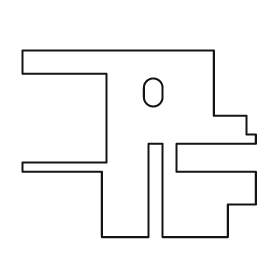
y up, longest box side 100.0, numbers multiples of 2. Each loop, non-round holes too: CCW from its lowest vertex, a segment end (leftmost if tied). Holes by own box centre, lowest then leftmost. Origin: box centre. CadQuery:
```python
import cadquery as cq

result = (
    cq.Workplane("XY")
    .moveTo(-16.0, -40.0)
    .lineTo(4.0, -40.0)
    .lineTo(4.0, 0.0)
    .lineTo(10.0, 0.0)
    .lineTo(10.0, -40.0)
    .lineTo(38.0, -40.0)
    .lineTo(38.0, -26.0)
    .lineTo(50.0, -26.0)
    .lineTo(50.0, -12.0)
    .lineTo(16.0, -12.0)
    .lineTo(16.0, 0.0)
    .lineTo(50.0, 0.0)
    .lineTo(50.0, 4.0)
    .lineTo(46.0, 4.0)
    .lineTo(46.0, 12.0)
    .lineTo(32.0, 12.0)
    .lineTo(32.0, 40.0)
    .lineTo(-50.0, 40.0)
    .lineTo(-50.0, 30.0)
    .lineTo(-14.0, 30.0)
    .lineTo(-14.0, -8.0)
    .lineTo(-50.0, -8.0)
    .lineTo(-50.0, -12.0)
    .lineTo(-16.0, -12.0)
    .close()
    .moveTo(2.0, 20.0)
    .threePointArc((6.0, 16.0), (10.0, 20.0))
    .lineTo(10.0, 24.0)
    .threePointArc((6.0, 28.0), (2.0, 24.0))
    .close()
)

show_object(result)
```